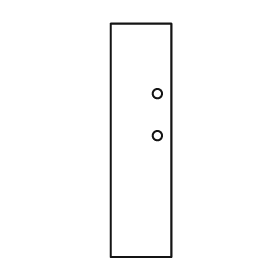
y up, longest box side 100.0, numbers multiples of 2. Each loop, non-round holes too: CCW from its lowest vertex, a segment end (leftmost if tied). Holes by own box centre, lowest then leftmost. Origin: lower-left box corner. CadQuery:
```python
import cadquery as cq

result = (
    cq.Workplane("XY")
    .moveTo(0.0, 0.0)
    .lineTo(26.0, 0.0)
    .lineTo(26.0, 100.0)
    .lineTo(0.0, 100.0)
    .close()
    .moveTo(20.0, 52.0)
    .circle(2.0)
    .moveTo(20.0, 70.0)
    .circle(2.0)
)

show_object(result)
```